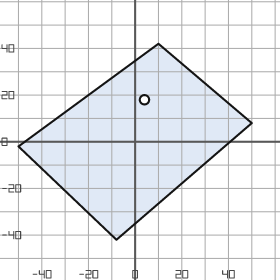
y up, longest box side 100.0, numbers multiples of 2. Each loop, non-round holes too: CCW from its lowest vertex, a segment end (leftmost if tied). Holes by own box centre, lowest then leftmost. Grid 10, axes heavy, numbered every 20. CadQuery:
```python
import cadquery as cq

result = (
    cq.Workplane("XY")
    .moveTo(-8.0, -42.0)
    .lineTo(50.0, 8.0)
    .lineTo(10.0, 42.0)
    .lineTo(-50.0, -2.0)
    .close()
    .moveTo(4.0, 18.0)
    .circle(2.0)
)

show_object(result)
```